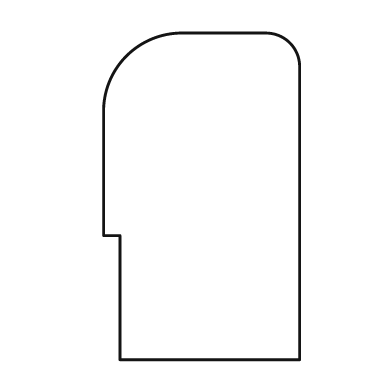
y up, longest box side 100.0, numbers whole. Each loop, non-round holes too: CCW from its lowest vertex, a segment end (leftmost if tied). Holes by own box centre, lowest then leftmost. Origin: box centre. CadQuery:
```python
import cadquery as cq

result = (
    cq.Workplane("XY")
    .moveTo(-25.0, -50.0)
    .lineTo(30.0, -50.0)
    .lineTo(30.0, 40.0)
    .threePointArc((27.0, 47.0), (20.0, 50.0))
    .lineTo(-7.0, 50.0)
    .threePointArc((-23.0, 43.0), (-30.0, 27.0))
    .lineTo(-30.0, -12.0)
    .lineTo(-25.0, -12.0)
    .close()
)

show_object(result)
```